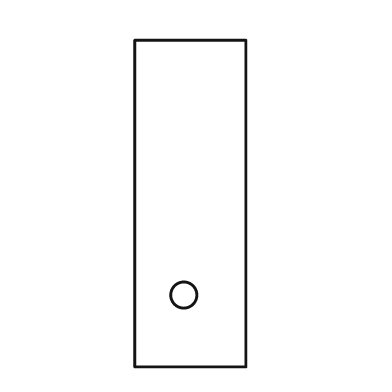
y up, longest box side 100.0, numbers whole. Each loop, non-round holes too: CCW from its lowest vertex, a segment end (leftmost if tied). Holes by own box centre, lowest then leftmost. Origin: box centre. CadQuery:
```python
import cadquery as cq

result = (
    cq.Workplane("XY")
    .moveTo(-17.0, -50.0)
    .lineTo(17.0, -50.0)
    .lineTo(17.0, 50.0)
    .lineTo(-17.0, 50.0)
    .close()
    .moveTo(-2.0, -28.0)
    .circle(4.0)
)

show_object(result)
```